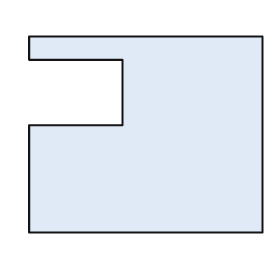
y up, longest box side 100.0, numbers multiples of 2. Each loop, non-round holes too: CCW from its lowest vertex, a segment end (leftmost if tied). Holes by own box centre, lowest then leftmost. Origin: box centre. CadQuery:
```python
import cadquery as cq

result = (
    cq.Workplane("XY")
    .moveTo(-50.0, -42.0)
    .lineTo(50.0, -42.0)
    .lineTo(50.0, 42.0)
    .lineTo(-50.0, 42.0)
    .lineTo(-50.0, 32.0)
    .lineTo(-10.0, 32.0)
    .lineTo(-10.0, 4.0)
    .lineTo(-50.0, 4.0)
    .close()
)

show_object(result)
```